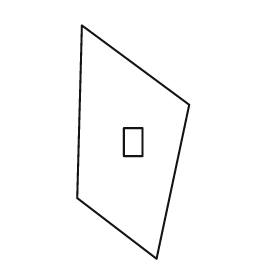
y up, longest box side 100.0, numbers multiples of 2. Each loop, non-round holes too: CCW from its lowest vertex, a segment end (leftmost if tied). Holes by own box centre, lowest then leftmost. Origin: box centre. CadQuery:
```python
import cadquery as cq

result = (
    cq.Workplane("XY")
    .moveTo(10.0, -50.0)
    .lineTo(24.0, 16.0)
    .lineTo(-22.0, 50.0)
    .lineTo(-24.0, -24.0)
    .close()
    .moveTo(-4.0, -6.0)
    .lineTo(4.0, -6.0)
    .lineTo(4.0, 6.0)
    .lineTo(-4.0, 6.0)
    .close()
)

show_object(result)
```